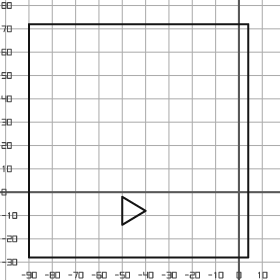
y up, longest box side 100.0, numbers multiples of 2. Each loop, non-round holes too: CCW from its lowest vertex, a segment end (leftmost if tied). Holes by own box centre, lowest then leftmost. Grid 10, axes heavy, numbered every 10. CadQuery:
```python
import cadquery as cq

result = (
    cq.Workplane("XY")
    .moveTo(-90.0, -28.0)
    .lineTo(4.0, -28.0)
    .lineTo(4.0, 72.0)
    .lineTo(-90.0, 72.0)
    .close()
    .moveTo(-50.0, -14.0)
    .lineTo(-40.0, -8.0)
    .lineTo(-50.0, -2.0)
    .close()
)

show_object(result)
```